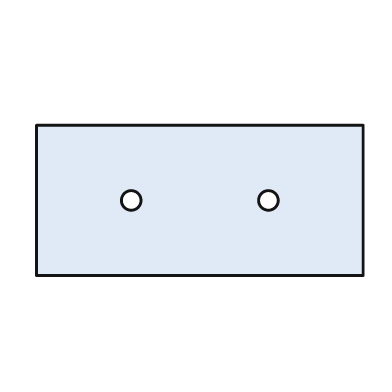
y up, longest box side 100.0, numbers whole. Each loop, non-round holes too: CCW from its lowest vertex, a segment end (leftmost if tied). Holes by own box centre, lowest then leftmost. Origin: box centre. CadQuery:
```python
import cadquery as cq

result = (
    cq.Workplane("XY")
    .moveTo(-50.0, -23.0)
    .lineTo(50.0, -23.0)
    .lineTo(50.0, 23.0)
    .lineTo(-50.0, 23.0)
    .close()
    .moveTo(-21.0, 0.0)
    .circle(3.0)
    .moveTo(21.0, 0.0)
    .circle(3.0)
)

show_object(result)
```